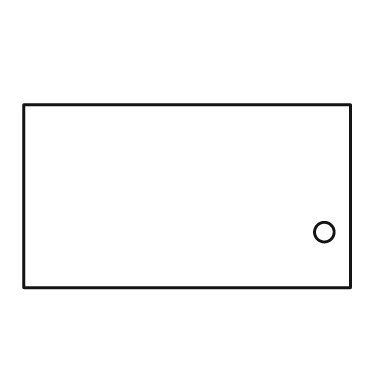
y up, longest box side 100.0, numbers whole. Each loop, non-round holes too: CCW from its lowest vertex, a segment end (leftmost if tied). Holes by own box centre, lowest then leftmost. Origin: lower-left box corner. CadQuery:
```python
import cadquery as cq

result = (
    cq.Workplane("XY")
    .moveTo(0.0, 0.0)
    .lineTo(100.0, 0.0)
    .lineTo(100.0, 56.0)
    .lineTo(0.0, 56.0)
    .close()
    .moveTo(92.0, 17.0)
    .circle(3.0)
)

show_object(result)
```